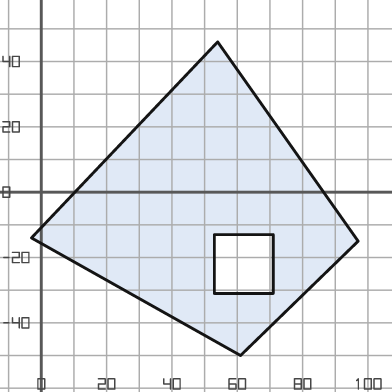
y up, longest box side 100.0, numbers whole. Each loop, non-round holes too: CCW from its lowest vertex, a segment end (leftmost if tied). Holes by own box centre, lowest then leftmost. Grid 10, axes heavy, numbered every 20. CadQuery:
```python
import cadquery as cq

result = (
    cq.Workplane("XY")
    .moveTo(61.0, -50.0)
    .lineTo(97.0, -15.0)
    .lineTo(54.0, 46.0)
    .lineTo(-3.0, -14.0)
    .close()
    .moveTo(53.0, -31.0)
    .lineTo(71.0, -31.0)
    .lineTo(71.0, -13.0)
    .lineTo(53.0, -13.0)
    .close()
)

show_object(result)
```